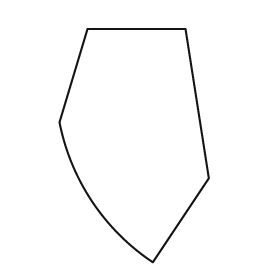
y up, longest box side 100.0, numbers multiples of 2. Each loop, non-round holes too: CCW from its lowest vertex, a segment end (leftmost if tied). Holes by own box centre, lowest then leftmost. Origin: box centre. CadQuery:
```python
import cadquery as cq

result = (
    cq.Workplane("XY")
    .moveTo(8.0, -50.0)
    .lineTo(32.0, -14.0)
    .lineTo(22.0, 50.0)
    .lineTo(-20.0, 50.0)
    .lineTo(-32.0, 10.0)
    .threePointArc((-18.0, -24.0), (8.0, -50.0))
    .close()
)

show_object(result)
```